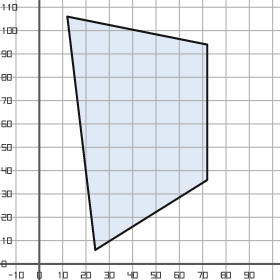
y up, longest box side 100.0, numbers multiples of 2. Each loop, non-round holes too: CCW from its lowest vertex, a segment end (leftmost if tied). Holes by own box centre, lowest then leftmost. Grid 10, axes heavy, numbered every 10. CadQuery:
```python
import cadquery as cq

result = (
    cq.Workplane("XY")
    .moveTo(24.0, 6.0)
    .lineTo(72.0, 36.0)
    .lineTo(72.0, 94.0)
    .lineTo(12.0, 106.0)
    .close()
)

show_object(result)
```